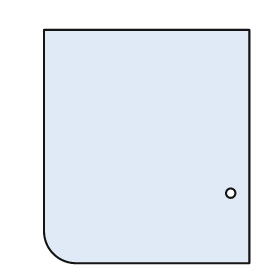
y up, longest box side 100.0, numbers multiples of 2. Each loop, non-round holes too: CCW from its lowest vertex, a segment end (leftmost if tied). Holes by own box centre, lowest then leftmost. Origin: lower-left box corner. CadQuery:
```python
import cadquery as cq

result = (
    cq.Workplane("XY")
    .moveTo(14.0, 0.0)
    .lineTo(88.0, 0.0)
    .lineTo(88.0, 100.0)
    .lineTo(0.0, 100.0)
    .lineTo(0.0, 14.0)
    .threePointArc((4.0, 4.0), (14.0, 0.0))
    .close()
    .moveTo(80.0, 30.0)
    .circle(2.0)
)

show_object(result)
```